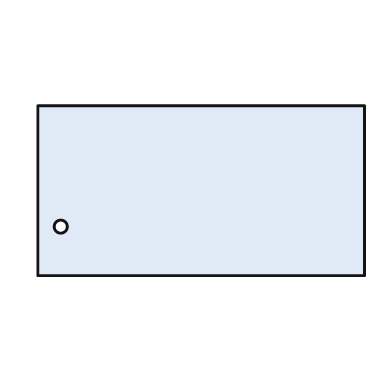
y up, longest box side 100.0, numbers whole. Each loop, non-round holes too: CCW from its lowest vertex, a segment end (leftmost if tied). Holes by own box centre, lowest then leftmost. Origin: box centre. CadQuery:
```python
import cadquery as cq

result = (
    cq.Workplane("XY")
    .moveTo(-50.0, -26.0)
    .lineTo(50.0, -26.0)
    .lineTo(50.0, 26.0)
    .lineTo(-50.0, 26.0)
    .close()
    .moveTo(-43.0, -11.0)
    .circle(2.0)
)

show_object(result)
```